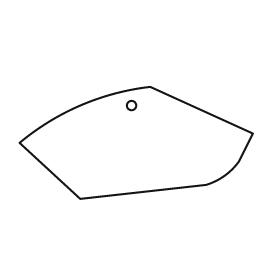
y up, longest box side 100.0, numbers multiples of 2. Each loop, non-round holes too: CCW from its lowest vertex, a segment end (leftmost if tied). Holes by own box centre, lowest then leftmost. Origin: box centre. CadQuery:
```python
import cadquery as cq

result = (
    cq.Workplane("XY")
    .moveTo(-24.0, -24.0)
    .lineTo(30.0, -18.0)
    .threePointArc((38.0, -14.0), (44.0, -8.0))
    .lineTo(50.0, 4.0)
    .lineTo(6.0, 24.0)
    .threePointArc((-24.0, 16.0), (-50.0, 0.0))
    .close()
    .moveTo(-2.0, 16.0)
    .circle(2.0)
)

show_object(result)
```